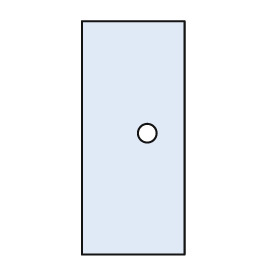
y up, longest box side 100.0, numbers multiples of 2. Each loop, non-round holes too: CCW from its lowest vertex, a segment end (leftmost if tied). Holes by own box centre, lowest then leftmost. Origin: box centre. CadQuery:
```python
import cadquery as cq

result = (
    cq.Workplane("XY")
    .moveTo(-22.0, -50.0)
    .lineTo(22.0, -50.0)
    .lineTo(22.0, 50.0)
    .lineTo(-22.0, 50.0)
    .close()
    .moveTo(6.0, 2.0)
    .circle(4.0)
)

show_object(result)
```